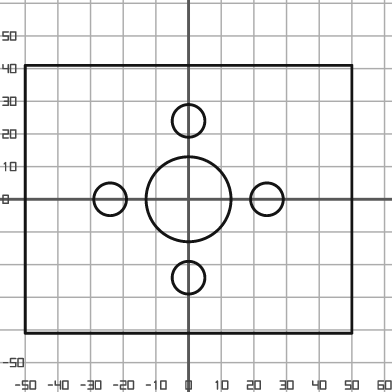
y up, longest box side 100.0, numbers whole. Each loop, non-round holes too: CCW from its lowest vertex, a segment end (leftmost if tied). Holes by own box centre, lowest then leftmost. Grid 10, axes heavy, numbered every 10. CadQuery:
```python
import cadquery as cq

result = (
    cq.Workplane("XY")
    .moveTo(-50.0, -41.0)
    .lineTo(50.0, -41.0)
    .lineTo(50.0, 41.0)
    .lineTo(-50.0, 41.0)
    .close()
    .moveTo(0.0, -24.0)
    .circle(5.0)
    .moveTo(-24.0, 0.0)
    .circle(5.0)
    .moveTo(0.0, 0.0)
    .circle(13.0)
    .moveTo(24.0, 0.0)
    .circle(5.0)
    .moveTo(0.0, 24.0)
    .circle(5.0)
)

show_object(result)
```